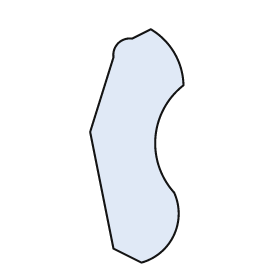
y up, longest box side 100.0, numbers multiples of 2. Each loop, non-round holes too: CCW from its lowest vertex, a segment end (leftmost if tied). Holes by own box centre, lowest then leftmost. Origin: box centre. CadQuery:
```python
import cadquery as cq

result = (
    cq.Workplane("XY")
    .moveTo(2.0, -50.0)
    .threePointArc((16.0, -38.0), (16.0, -20.0))
    .threePointArc((8.0, 4.0), (20.0, 26.0))
    .threePointArc((16.0, 40.0), (6.0, 50.0))
    .lineTo(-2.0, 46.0)
    .threePointArc((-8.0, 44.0), (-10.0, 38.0))
    .lineTo(-20.0, 6.0)
    .lineTo(-10.0, -44.0)
    .close()
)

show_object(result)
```